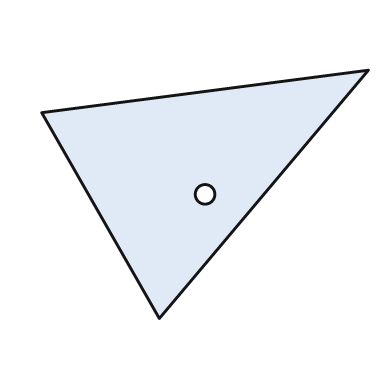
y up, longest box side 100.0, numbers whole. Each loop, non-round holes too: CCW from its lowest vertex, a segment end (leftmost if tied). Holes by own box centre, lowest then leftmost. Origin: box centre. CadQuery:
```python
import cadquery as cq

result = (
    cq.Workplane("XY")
    .moveTo(-14.0, -38.0)
    .lineTo(50.0, 38.0)
    .lineTo(-50.0, 25.0)
    .close()
    .moveTo(0.0, 0.0)
    .circle(3.0)
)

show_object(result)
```